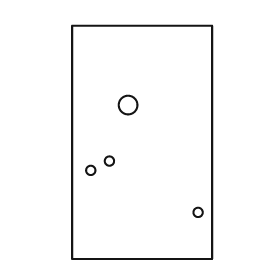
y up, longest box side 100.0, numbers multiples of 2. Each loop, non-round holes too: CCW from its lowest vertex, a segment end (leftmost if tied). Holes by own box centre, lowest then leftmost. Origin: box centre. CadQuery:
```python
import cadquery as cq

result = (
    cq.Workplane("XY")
    .moveTo(-30.0, -50.0)
    .lineTo(30.0, -50.0)
    .lineTo(30.0, 50.0)
    .lineTo(-30.0, 50.0)
    .close()
    .moveTo(24.0, -30.0)
    .circle(2.0)
    .moveTo(-22.0, -12.0)
    .circle(2.0)
    .moveTo(-14.0, -8.0)
    .circle(2.0)
    .moveTo(-6.0, 16.0)
    .circle(4.0)
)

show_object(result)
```